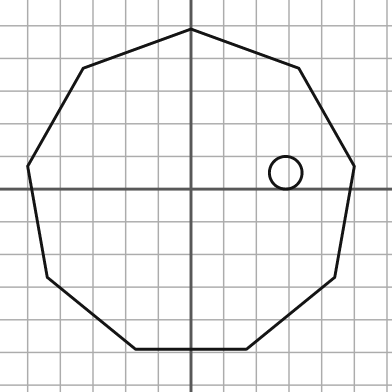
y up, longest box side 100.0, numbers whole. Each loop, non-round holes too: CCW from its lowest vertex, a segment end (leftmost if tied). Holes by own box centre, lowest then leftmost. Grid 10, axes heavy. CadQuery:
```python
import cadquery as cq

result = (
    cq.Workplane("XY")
    .moveTo(-17.0, -49.0)
    .lineTo(17.0, -49.0)
    .lineTo(44.0, -27.0)
    .lineTo(50.0, 7.0)
    .lineTo(33.0, 37.0)
    .lineTo(0.0, 49.0)
    .lineTo(-33.0, 37.0)
    .lineTo(-50.0, 7.0)
    .lineTo(-44.0, -27.0)
    .close()
    .moveTo(29.0, 5.0)
    .circle(5.0)
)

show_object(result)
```